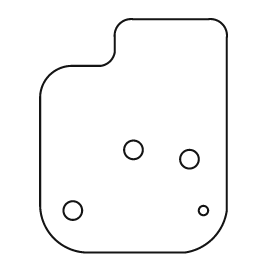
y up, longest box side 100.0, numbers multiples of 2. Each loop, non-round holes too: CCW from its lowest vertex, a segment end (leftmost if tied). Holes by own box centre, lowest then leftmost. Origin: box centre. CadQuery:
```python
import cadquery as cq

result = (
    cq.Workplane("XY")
    .moveTo(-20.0, -50.0)
    .lineTo(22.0, -50.0)
    .threePointArc((34.0, -44.0), (40.0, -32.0))
    .lineTo(40.0, 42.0)
    .threePointArc((38.0, 48.0), (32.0, 50.0))
    .lineTo(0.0, 50.0)
    .threePointArc((-6.0, 48.0), (-8.0, 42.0))
    .lineTo(-8.0, 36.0)
    .threePointArc((-10.0, 32.0), (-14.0, 30.0))
    .lineTo(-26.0, 30.0)
    .threePointArc((-36.0, 26.0), (-40.0, 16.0))
    .lineTo(-40.0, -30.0)
    .threePointArc((-34.0, -44.0), (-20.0, -50.0))
    .close()
    .moveTo(-26.0, -32.0)
    .circle(4.0)
    .moveTo(30.0, -32.0)
    .circle(2.0)
    .moveTo(24.0, -10.0)
    .circle(4.0)
    .moveTo(0.0, -6.0)
    .circle(4.0)
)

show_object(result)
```